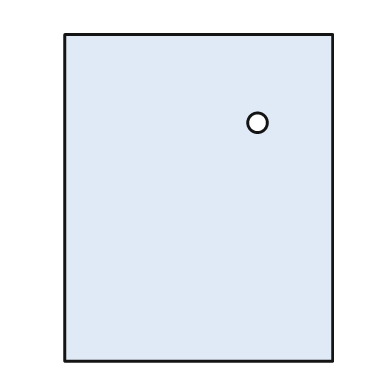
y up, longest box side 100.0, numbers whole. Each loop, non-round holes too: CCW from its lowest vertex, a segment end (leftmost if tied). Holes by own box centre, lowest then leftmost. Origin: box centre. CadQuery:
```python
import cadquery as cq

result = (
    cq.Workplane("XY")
    .moveTo(-41.0, -50.0)
    .lineTo(41.0, -50.0)
    .lineTo(41.0, 50.0)
    .lineTo(-41.0, 50.0)
    .close()
    .moveTo(18.0, 23.0)
    .circle(3.0)
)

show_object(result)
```